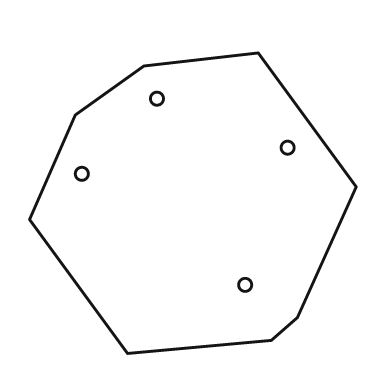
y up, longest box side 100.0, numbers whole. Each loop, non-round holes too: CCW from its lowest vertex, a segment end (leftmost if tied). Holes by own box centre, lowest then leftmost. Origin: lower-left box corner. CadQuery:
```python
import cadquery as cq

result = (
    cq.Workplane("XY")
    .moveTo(30.0, 0.0)
    .lineTo(74.0, 4.0)
    .lineTo(82.0, 11.0)
    .lineTo(100.0, 51.0)
    .lineTo(70.0, 92.0)
    .lineTo(35.0, 88.0)
    .lineTo(14.0, 73.0)
    .lineTo(0.0, 41.0)
    .close()
    .moveTo(66.0, 21.0)
    .circle(2.0)
    .moveTo(16.0, 55.0)
    .circle(2.0)
    .moveTo(79.0, 63.0)
    .circle(2.0)
    .moveTo(39.0, 78.0)
    .circle(2.0)
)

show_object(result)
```